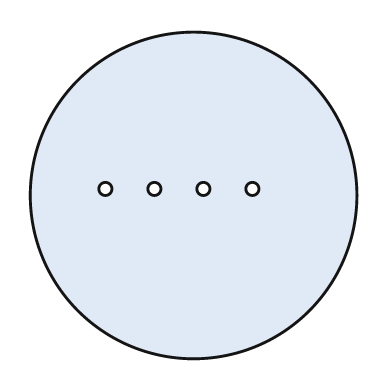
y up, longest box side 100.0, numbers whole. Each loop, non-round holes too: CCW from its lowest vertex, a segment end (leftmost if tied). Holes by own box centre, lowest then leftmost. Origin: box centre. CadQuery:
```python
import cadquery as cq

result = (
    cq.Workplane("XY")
    .moveTo(0.0, 0.0)
    .circle(50.0)
    .moveTo(-27.0, 2.0)
    .circle(2.0)
    .moveTo(-12.0, 2.0)
    .circle(2.0)
    .moveTo(3.0, 2.0)
    .circle(2.0)
    .moveTo(18.0, 2.0)
    .circle(2.0)
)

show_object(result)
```